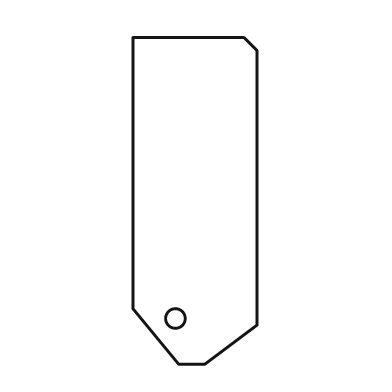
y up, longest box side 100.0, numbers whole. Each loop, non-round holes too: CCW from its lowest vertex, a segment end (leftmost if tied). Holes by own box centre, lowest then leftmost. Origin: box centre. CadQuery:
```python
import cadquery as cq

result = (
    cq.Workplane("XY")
    .moveTo(-5.0, -50.0)
    .lineTo(3.0, -50.0)
    .lineTo(19.0, -38.0)
    .lineTo(19.0, 46.0)
    .lineTo(15.0, 50.0)
    .lineTo(-19.0, 50.0)
    .lineTo(-19.0, -33.0)
    .close()
    .moveTo(-6.0, -36.0)
    .circle(3.0)
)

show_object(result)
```